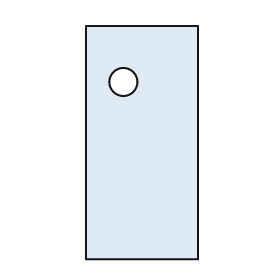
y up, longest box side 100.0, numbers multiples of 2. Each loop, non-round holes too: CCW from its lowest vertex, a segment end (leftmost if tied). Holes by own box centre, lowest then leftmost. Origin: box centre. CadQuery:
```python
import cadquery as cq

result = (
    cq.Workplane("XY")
    .moveTo(-24.0, -50.0)
    .lineTo(24.0, -50.0)
    .lineTo(24.0, 50.0)
    .lineTo(-24.0, 50.0)
    .close()
    .moveTo(-8.0, 26.0)
    .circle(6.0)
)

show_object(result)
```